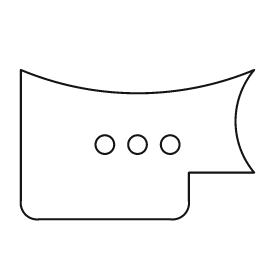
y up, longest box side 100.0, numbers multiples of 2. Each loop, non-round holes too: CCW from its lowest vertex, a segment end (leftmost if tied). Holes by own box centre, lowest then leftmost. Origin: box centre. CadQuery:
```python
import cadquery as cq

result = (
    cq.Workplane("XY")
    .moveTo(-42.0, -32.0)
    .lineTo(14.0, -32.0)
    .threePointArc((20.0, -30.0), (22.0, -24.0))
    .lineTo(22.0, -12.0)
    .lineTo(50.0, -12.0)
    .threePointArc((42.0, 10.0), (50.0, 32.0))
    .threePointArc((0.0, 22.0), (-50.0, 32.0))
    .lineTo(-50.0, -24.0)
    .threePointArc((-48.0, -30.0), (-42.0, -32.0))
    .close()
    .moveTo(-14.0, 0.0)
    .circle(4.0)
    .moveTo(0.0, 0.0)
    .circle(4.0)
    .moveTo(14.0, 0.0)
    .circle(4.0)
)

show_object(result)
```